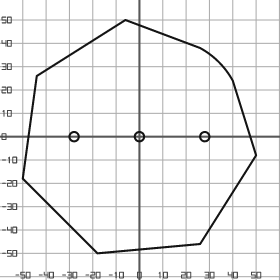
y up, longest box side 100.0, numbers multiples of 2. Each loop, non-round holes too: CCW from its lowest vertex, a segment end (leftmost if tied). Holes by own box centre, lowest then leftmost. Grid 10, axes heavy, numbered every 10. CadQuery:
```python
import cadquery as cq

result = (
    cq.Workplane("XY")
    .moveTo(-18.0, -50.0)
    .lineTo(26.0, -46.0)
    .lineTo(50.0, -8.0)
    .lineTo(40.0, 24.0)
    .threePointArc((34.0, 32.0), (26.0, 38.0))
    .lineTo(-6.0, 50.0)
    .lineTo(-44.0, 26.0)
    .lineTo(-50.0, -18.0)
    .close()
    .moveTo(-28.0, 0.0)
    .circle(2.0)
    .moveTo(0.0, 0.0)
    .circle(2.0)
    .moveTo(28.0, 0.0)
    .circle(2.0)
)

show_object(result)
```